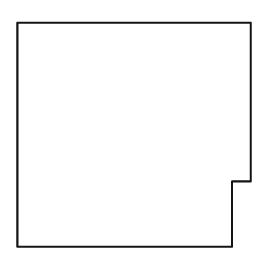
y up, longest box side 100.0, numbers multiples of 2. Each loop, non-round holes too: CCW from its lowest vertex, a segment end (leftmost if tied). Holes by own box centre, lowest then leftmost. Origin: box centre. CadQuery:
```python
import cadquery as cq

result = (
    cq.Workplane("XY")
    .moveTo(-50.0, -48.0)
    .lineTo(42.0, -48.0)
    .lineTo(42.0, -20.0)
    .lineTo(50.0, -20.0)
    .lineTo(50.0, 48.0)
    .lineTo(-50.0, 48.0)
    .close()
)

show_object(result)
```